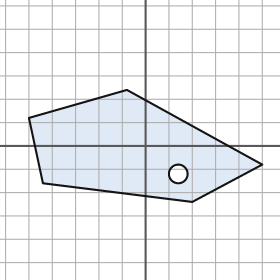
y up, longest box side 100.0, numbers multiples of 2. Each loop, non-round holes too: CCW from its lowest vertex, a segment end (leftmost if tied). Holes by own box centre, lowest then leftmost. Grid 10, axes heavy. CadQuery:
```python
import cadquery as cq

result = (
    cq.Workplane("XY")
    .moveTo(20.0, -24.0)
    .lineTo(50.0, -8.0)
    .lineTo(-8.0, 24.0)
    .lineTo(-50.0, 12.0)
    .lineTo(-44.0, -16.0)
    .close()
    .moveTo(14.0, -12.0)
    .circle(4.0)
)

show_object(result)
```